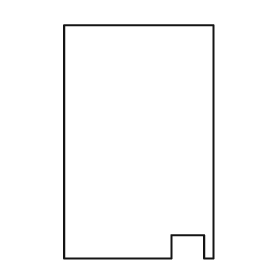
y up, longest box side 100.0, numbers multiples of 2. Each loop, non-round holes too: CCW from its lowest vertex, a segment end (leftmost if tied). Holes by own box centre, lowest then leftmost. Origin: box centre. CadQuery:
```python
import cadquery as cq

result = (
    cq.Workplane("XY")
    .moveTo(-32.0, -50.0)
    .lineTo(14.0, -50.0)
    .lineTo(14.0, -40.0)
    .lineTo(28.0, -40.0)
    .lineTo(28.0, -50.0)
    .lineTo(32.0, -50.0)
    .lineTo(32.0, 50.0)
    .lineTo(-32.0, 50.0)
    .close()
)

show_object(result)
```